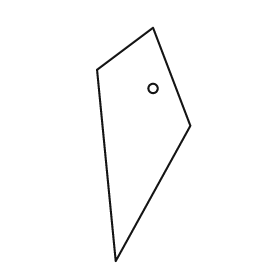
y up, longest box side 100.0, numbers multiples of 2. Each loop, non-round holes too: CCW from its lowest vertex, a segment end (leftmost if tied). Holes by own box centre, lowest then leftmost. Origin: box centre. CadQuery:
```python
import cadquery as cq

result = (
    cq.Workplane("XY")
    .moveTo(-12.0, -50.0)
    .lineTo(20.0, 8.0)
    .lineTo(4.0, 50.0)
    .lineTo(-20.0, 32.0)
    .close()
    .moveTo(4.0, 24.0)
    .circle(2.0)
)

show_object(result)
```